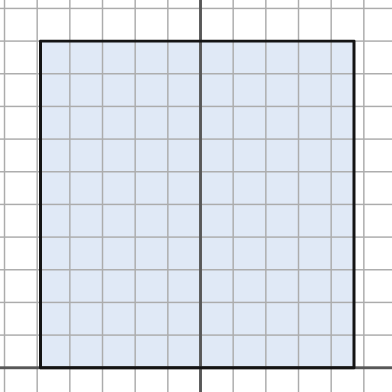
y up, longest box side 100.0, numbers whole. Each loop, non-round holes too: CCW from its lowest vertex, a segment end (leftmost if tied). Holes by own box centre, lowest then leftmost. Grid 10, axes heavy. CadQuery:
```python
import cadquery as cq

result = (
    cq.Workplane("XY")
    .moveTo(-49.0, 0.0)
    .lineTo(47.0, 0.0)
    .lineTo(47.0, 100.0)
    .lineTo(-49.0, 100.0)
    .close()
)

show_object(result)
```